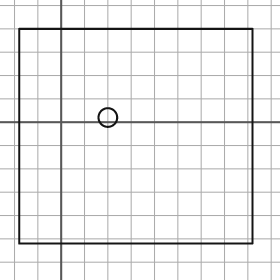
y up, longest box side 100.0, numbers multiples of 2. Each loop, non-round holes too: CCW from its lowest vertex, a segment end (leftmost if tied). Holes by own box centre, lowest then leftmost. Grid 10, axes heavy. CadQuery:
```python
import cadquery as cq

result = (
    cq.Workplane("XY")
    .moveTo(-18.0, -52.0)
    .lineTo(82.0, -52.0)
    .lineTo(82.0, 40.0)
    .lineTo(-18.0, 40.0)
    .close()
    .moveTo(20.0, 2.0)
    .circle(4.0)
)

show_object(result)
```